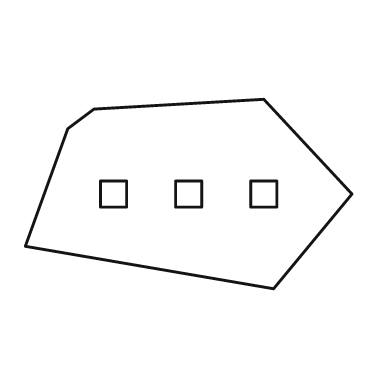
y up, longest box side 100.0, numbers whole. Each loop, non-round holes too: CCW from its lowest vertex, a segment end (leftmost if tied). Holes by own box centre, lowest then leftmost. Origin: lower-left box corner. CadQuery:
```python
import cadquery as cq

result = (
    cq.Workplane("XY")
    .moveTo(76.0, 0.0)
    .lineTo(100.0, 29.0)
    .lineTo(73.0, 58.0)
    .lineTo(21.0, 55.0)
    .lineTo(13.0, 49.0)
    .lineTo(0.0, 13.0)
    .close()
    .moveTo(23.0, 25.0)
    .lineTo(31.0, 25.0)
    .lineTo(31.0, 33.0)
    .lineTo(23.0, 33.0)
    .close()
    .moveTo(46.0, 25.0)
    .lineTo(54.0, 25.0)
    .lineTo(54.0, 33.0)
    .lineTo(46.0, 33.0)
    .close()
    .moveTo(69.0, 25.0)
    .lineTo(77.0, 25.0)
    .lineTo(77.0, 33.0)
    .lineTo(69.0, 33.0)
    .close()
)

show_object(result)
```